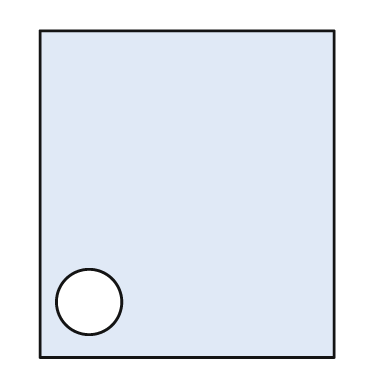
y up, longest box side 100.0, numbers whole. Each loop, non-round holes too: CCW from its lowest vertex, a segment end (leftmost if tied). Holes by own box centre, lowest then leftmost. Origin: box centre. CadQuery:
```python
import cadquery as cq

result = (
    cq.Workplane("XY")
    .moveTo(-45.0, -50.0)
    .lineTo(45.0, -50.0)
    .lineTo(45.0, 50.0)
    .lineTo(-45.0, 50.0)
    .close()
    .moveTo(-30.0, -33.0)
    .circle(10.0)
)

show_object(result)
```